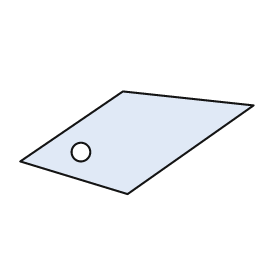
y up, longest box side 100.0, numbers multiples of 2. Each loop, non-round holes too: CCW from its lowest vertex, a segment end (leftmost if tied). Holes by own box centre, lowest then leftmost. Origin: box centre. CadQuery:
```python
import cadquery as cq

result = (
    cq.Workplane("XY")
    .moveTo(-4.0, -22.0)
    .lineTo(50.0, 16.0)
    .lineTo(-6.0, 22.0)
    .lineTo(-50.0, -8.0)
    .close()
    .moveTo(-24.0, -4.0)
    .circle(4.0)
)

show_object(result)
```